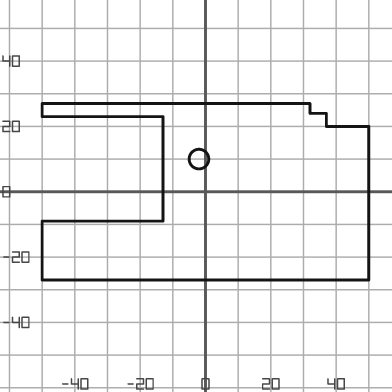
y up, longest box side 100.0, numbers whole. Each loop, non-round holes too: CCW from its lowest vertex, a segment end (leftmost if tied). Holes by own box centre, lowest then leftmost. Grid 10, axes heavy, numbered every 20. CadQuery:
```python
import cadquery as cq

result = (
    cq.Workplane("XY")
    .moveTo(-50.0, -27.0)
    .lineTo(50.0, -27.0)
    .lineTo(50.0, 20.0)
    .lineTo(37.0, 20.0)
    .lineTo(37.0, 24.0)
    .lineTo(32.0, 24.0)
    .lineTo(32.0, 27.0)
    .lineTo(-50.0, 27.0)
    .lineTo(-50.0, 23.0)
    .lineTo(-13.0, 23.0)
    .lineTo(-13.0, -9.0)
    .lineTo(-50.0, -9.0)
    .close()
    .moveTo(-2.0, 10.0)
    .circle(3.0)
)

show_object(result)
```